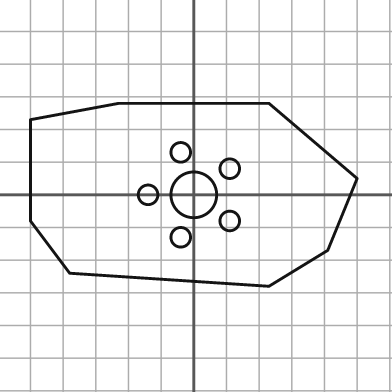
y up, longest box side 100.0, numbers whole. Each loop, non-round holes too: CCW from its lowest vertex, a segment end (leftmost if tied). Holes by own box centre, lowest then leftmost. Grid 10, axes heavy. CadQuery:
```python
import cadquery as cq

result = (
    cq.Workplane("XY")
    .moveTo(23.0, -28.0)
    .lineTo(41.0, -17.0)
    .lineTo(50.0, 5.0)
    .lineTo(23.0, 28.0)
    .lineTo(-23.0, 28.0)
    .lineTo(-50.0, 23.0)
    .lineTo(-50.0, -8.0)
    .lineTo(-38.0, -24.0)
    .close()
    .moveTo(-4.0, -13.0)
    .circle(3.0)
    .moveTo(11.0, -8.0)
    .circle(3.0)
    .moveTo(-14.0, 0.0)
    .circle(3.0)
    .moveTo(0.0, 0.0)
    .circle(7.0)
    .moveTo(11.0, 8.0)
    .circle(3.0)
    .moveTo(-4.0, 13.0)
    .circle(3.0)
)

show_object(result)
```